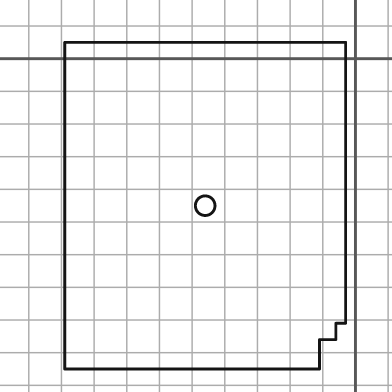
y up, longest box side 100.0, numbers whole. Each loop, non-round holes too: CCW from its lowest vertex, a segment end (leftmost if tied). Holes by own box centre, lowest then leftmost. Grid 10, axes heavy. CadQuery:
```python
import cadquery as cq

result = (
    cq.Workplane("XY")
    .moveTo(-89.0, -95.0)
    .lineTo(-11.0, -95.0)
    .lineTo(-11.0, -86.0)
    .lineTo(-6.0, -86.0)
    .lineTo(-6.0, -81.0)
    .lineTo(-3.0, -81.0)
    .lineTo(-3.0, 5.0)
    .lineTo(-89.0, 5.0)
    .close()
    .moveTo(-46.0, -45.0)
    .circle(3.0)
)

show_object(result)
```